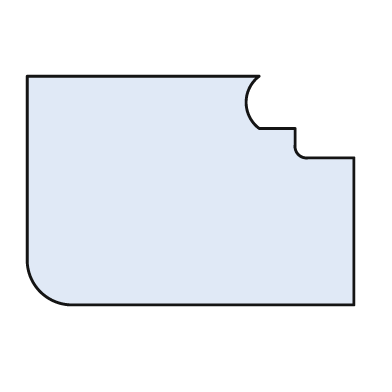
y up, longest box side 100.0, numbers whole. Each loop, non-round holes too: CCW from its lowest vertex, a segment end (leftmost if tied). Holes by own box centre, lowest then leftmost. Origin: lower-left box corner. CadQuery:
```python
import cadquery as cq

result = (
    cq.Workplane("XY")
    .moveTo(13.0, 0.0)
    .lineTo(100.0, 0.0)
    .lineTo(100.0, 45.0)
    .lineTo(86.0, 45.0)
    .threePointArc((83.0, 46.0), (82.0, 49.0))
    .lineTo(82.0, 54.0)
    .lineTo(71.0, 54.0)
    .threePointArc((67.0, 62.0), (71.0, 70.0))
    .lineTo(0.0, 70.0)
    .lineTo(0.0, 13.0)
    .threePointArc((4.0, 4.0), (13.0, 0.0))
    .close()
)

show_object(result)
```